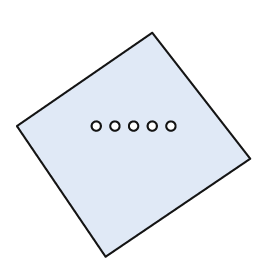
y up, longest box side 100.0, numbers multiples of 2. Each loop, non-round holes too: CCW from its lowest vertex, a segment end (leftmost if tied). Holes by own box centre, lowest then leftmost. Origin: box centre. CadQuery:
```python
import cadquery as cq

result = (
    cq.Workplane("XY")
    .moveTo(-12.0, -48.0)
    .lineTo(50.0, -6.0)
    .lineTo(8.0, 48.0)
    .lineTo(-50.0, 8.0)
    .close()
    .moveTo(-16.0, 8.0)
    .circle(2.0)
    .moveTo(-8.0, 8.0)
    .circle(2.0)
    .moveTo(0.0, 8.0)
    .circle(2.0)
    .moveTo(8.0, 8.0)
    .circle(2.0)
    .moveTo(16.0, 8.0)
    .circle(2.0)
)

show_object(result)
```